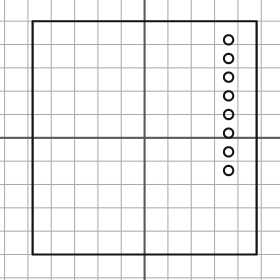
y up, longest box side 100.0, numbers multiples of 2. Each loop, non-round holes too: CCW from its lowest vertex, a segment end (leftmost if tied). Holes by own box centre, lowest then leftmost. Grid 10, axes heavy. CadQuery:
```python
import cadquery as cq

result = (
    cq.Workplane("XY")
    .moveTo(-48.0, -50.0)
    .lineTo(48.0, -50.0)
    .lineTo(48.0, 50.0)
    .lineTo(-48.0, 50.0)
    .close()
    .moveTo(36.0, -14.0)
    .circle(2.0)
    .moveTo(36.0, -6.0)
    .circle(2.0)
    .moveTo(36.0, 2.0)
    .circle(2.0)
    .moveTo(36.0, 10.0)
    .circle(2.0)
    .moveTo(36.0, 18.0)
    .circle(2.0)
    .moveTo(36.0, 26.0)
    .circle(2.0)
    .moveTo(36.0, 34.0)
    .circle(2.0)
    .moveTo(36.0, 42.0)
    .circle(2.0)
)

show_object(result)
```